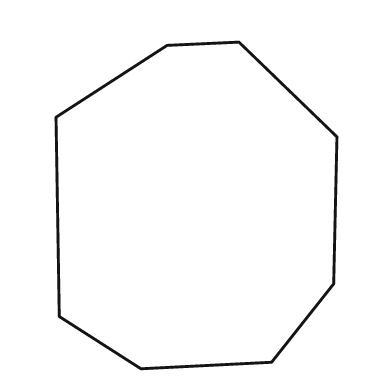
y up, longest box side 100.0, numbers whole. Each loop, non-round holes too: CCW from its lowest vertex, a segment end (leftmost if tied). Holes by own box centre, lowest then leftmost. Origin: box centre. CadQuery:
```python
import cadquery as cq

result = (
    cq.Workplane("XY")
    .moveTo(-17.0, -50.0)
    .lineTo(23.0, -48.0)
    .lineTo(42.0, -24.0)
    .lineTo(43.0, 21.0)
    .lineTo(13.0, 50.0)
    .lineTo(-9.0, 49.0)
    .lineTo(-43.0, 27.0)
    .lineTo(-42.0, -34.0)
    .close()
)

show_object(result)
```